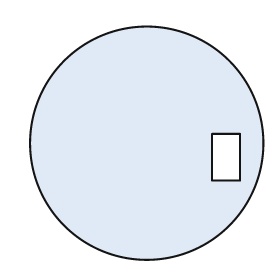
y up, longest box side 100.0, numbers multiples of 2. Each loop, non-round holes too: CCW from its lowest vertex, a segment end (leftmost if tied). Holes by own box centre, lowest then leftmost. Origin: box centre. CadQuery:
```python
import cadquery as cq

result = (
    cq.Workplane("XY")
    .moveTo(0.0, 0.0)
    .circle(50.0)
    .moveTo(28.0, -16.0)
    .lineTo(40.0, -16.0)
    .lineTo(40.0, 4.0)
    .lineTo(28.0, 4.0)
    .close()
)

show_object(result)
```